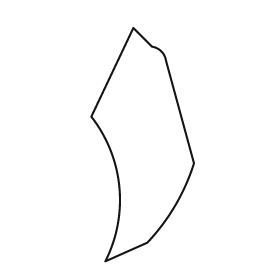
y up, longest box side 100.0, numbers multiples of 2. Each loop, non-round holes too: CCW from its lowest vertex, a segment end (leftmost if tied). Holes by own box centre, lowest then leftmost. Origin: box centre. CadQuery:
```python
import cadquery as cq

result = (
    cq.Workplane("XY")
    .moveTo(-16.0, -50.0)
    .lineTo(2.0, -42.0)
    .threePointArc((14.0, -26.0), (22.0, -8.0))
    .lineTo(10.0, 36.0)
    .threePointArc((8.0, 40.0), (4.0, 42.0))
    .lineTo(-4.0, 50.0)
    .lineTo(-22.0, 12.0)
    .threePointArc((-10.0, -18.0), (-16.0, -50.0))
    .close()
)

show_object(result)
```